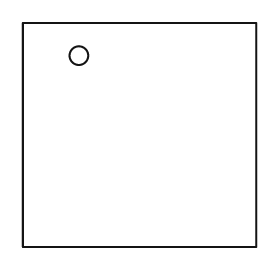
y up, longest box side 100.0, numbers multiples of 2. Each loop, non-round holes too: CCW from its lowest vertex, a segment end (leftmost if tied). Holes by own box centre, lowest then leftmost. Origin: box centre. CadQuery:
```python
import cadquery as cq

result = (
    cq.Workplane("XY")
    .moveTo(-50.0, -48.0)
    .lineTo(50.0, -48.0)
    .lineTo(50.0, 48.0)
    .lineTo(-50.0, 48.0)
    .close()
    .moveTo(-26.0, 34.0)
    .circle(4.0)
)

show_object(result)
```